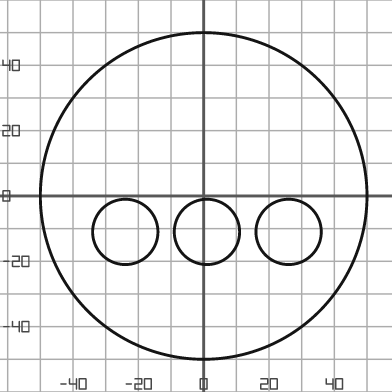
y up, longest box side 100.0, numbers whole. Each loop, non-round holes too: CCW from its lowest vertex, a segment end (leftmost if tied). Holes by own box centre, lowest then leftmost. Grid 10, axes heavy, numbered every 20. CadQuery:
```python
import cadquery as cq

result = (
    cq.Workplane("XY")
    .moveTo(0.0, 0.0)
    .circle(50.0)
    .moveTo(-24.0, -11.0)
    .circle(10.0)
    .moveTo(1.0, -11.0)
    .circle(10.0)
    .moveTo(26.0, -11.0)
    .circle(10.0)
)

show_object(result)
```